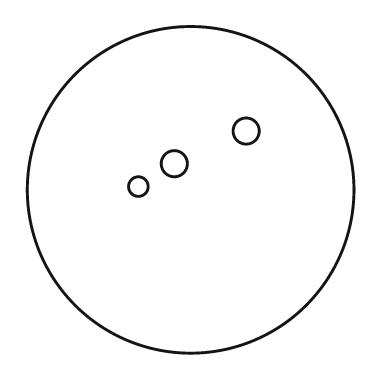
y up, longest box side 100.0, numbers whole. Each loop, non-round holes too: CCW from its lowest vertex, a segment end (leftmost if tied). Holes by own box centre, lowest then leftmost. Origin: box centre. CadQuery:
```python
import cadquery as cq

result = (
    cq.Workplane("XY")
    .moveTo(0.0, 0.0)
    .circle(50.0)
    .moveTo(-16.0, 1.0)
    .circle(3.0)
    .moveTo(-5.0, 8.0)
    .circle(4.0)
    .moveTo(17.0, 18.0)
    .circle(4.0)
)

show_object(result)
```